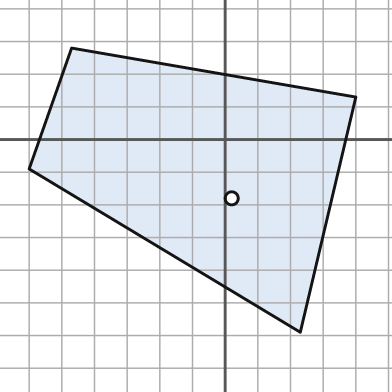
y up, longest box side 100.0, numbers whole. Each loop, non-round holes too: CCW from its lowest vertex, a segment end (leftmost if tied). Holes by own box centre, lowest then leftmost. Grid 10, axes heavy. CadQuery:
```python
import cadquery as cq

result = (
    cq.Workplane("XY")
    .moveTo(23.0, -59.0)
    .lineTo(40.0, 13.0)
    .lineTo(-47.0, 28.0)
    .lineTo(-60.0, -9.0)
    .close()
    .moveTo(2.0, -18.0)
    .circle(2.0)
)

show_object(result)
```